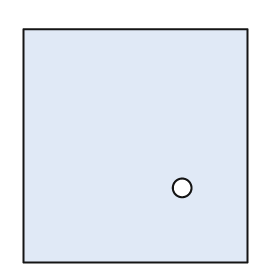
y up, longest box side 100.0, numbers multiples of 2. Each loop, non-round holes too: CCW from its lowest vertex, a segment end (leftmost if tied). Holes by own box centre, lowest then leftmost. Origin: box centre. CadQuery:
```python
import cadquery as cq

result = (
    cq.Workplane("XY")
    .moveTo(-48.0, -50.0)
    .lineTo(48.0, -50.0)
    .lineTo(48.0, 50.0)
    .lineTo(-48.0, 50.0)
    .close()
    .moveTo(20.0, -18.0)
    .circle(4.0)
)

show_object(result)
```